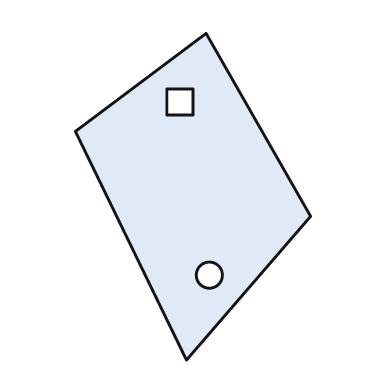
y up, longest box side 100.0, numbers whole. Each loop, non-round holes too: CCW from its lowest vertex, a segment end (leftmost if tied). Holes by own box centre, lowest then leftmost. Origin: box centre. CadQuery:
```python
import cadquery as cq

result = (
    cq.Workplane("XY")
    .moveTo(-2.0, -50.0)
    .lineTo(36.0, -6.0)
    .lineTo(4.0, 50.0)
    .lineTo(-36.0, 20.0)
    .close()
    .moveTo(5.0, -24.0)
    .circle(4.0)
    .moveTo(-8.0, 25.0)
    .lineTo(0.0, 25.0)
    .lineTo(0.0, 33.0)
    .lineTo(-8.0, 33.0)
    .close()
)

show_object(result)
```